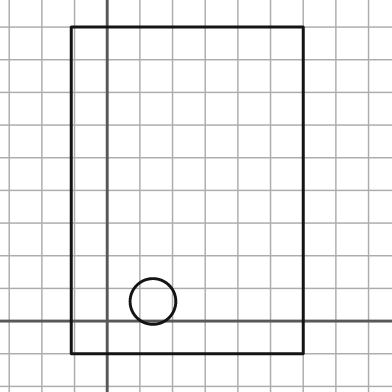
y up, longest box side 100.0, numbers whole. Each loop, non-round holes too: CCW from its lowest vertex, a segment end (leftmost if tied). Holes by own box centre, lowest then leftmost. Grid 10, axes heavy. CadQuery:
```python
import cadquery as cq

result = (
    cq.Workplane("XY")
    .moveTo(-11.0, -10.0)
    .lineTo(60.0, -10.0)
    .lineTo(60.0, 90.0)
    .lineTo(-11.0, 90.0)
    .close()
    .moveTo(14.0, 6.0)
    .circle(7.0)
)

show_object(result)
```